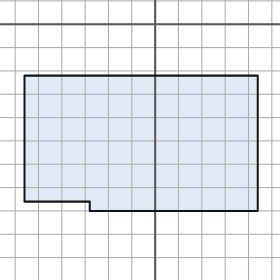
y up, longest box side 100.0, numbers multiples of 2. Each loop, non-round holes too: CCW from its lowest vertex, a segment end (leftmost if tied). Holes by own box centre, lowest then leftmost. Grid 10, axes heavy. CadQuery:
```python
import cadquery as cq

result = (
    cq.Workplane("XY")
    .moveTo(-28.0, -80.0)
    .lineTo(44.0, -80.0)
    .lineTo(44.0, -22.0)
    .lineTo(-56.0, -22.0)
    .lineTo(-56.0, -76.0)
    .lineTo(-28.0, -76.0)
    .close()
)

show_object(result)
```